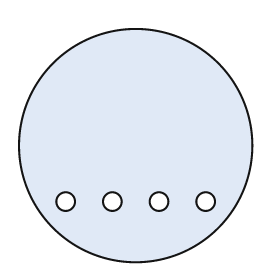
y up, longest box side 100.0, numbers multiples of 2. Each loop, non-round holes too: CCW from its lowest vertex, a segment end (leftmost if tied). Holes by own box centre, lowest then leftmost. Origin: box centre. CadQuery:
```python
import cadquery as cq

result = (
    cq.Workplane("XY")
    .moveTo(0.0, 0.0)
    .circle(50.0)
    .moveTo(-30.0, -24.0)
    .circle(4.0)
    .moveTo(-10.0, -24.0)
    .circle(4.0)
    .moveTo(10.0, -24.0)
    .circle(4.0)
    .moveTo(30.0, -24.0)
    .circle(4.0)
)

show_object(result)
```